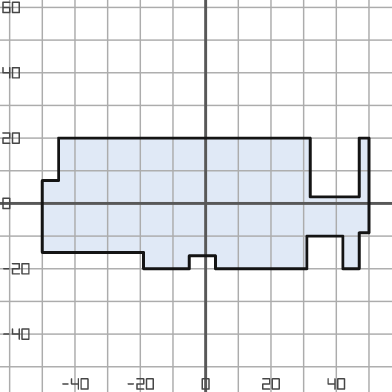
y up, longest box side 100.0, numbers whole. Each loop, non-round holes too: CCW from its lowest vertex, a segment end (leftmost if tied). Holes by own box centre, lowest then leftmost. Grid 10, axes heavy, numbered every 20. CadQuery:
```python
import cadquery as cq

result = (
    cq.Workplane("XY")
    .moveTo(-19.0, -20.0)
    .lineTo(-5.0, -20.0)
    .lineTo(-5.0, -16.0)
    .lineTo(3.0, -16.0)
    .lineTo(3.0, -20.0)
    .lineTo(31.0, -20.0)
    .lineTo(31.0, -10.0)
    .lineTo(42.0, -10.0)
    .lineTo(42.0, -20.0)
    .lineTo(47.0, -20.0)
    .lineTo(47.0, -9.0)
    .lineTo(50.0, -9.0)
    .lineTo(50.0, 20.0)
    .lineTo(47.0, 20.0)
    .lineTo(47.0, 2.0)
    .lineTo(32.0, 2.0)
    .lineTo(32.0, 20.0)
    .lineTo(-45.0, 20.0)
    .lineTo(-45.0, 7.0)
    .lineTo(-50.0, 7.0)
    .lineTo(-50.0, -15.0)
    .lineTo(-19.0, -15.0)
    .close()
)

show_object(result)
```